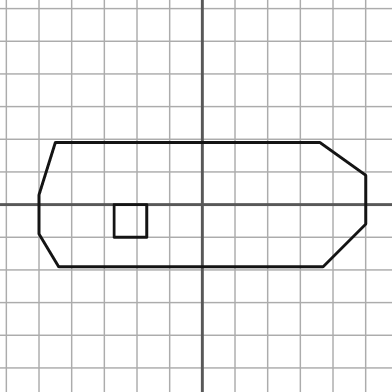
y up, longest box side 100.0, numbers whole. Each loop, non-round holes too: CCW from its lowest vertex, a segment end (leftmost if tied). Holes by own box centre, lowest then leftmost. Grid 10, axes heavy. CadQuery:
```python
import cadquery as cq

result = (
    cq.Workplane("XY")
    .moveTo(-44.0, -19.0)
    .lineTo(37.0, -19.0)
    .lineTo(50.0, -6.0)
    .lineTo(50.0, 9.0)
    .lineTo(36.0, 19.0)
    .lineTo(-45.0, 19.0)
    .lineTo(-50.0, 3.0)
    .lineTo(-50.0, -9.0)
    .close()
    .moveTo(-27.0, -10.0)
    .lineTo(-17.0, -10.0)
    .lineTo(-17.0, 0.0)
    .lineTo(-27.0, 0.0)
    .close()
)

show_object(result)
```